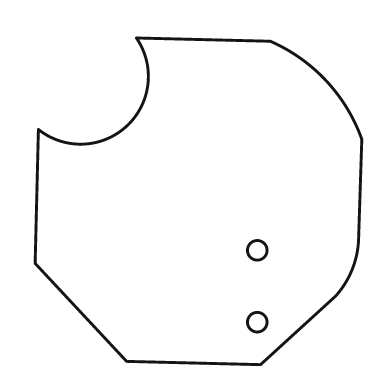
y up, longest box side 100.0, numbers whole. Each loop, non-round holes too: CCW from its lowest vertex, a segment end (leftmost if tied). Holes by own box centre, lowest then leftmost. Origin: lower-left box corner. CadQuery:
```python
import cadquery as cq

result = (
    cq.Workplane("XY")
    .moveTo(69.0, 0.0)
    .lineTo(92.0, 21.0)
    .threePointArc((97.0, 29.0), (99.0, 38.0))
    .lineTo(100.0, 69.0)
    .threePointArc((89.0, 87.0), (72.0, 99.0))
    .lineTo(31.0, 100.0)
    .threePointArc((28.0, 73.0), (1.0, 72.0))
    .lineTo(0.0, 31.0)
    .lineTo(28.0, 1.0)
    .close()
    .moveTo(68.0, 13.0)
    .circle(3.0)
    .moveTo(68.0, 35.0)
    .circle(3.0)
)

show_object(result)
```